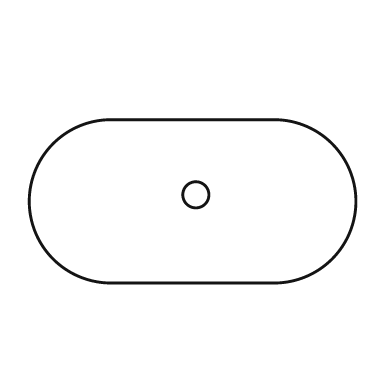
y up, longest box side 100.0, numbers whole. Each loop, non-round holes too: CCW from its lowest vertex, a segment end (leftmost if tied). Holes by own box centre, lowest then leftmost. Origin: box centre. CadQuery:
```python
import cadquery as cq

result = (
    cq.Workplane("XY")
    .moveTo(-25.0, -25.0)
    .lineTo(25.0, -25.0)
    .threePointArc((50.0, 0.0), (25.0, 25.0))
    .lineTo(-25.0, 25.0)
    .threePointArc((-50.0, 0.0), (-25.0, -25.0))
    .close()
    .moveTo(1.0, 2.0)
    .circle(4.0)
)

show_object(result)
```